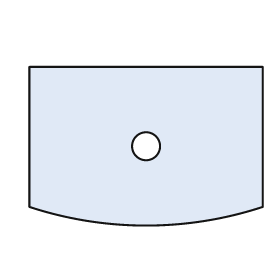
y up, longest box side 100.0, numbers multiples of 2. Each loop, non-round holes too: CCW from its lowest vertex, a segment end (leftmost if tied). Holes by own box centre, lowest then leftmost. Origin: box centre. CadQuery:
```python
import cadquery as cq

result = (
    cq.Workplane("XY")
    .moveTo(-50.0, -26.0)
    .threePointArc((0.0, -34.0), (50.0, -26.0))
    .lineTo(50.0, 34.0)
    .lineTo(-50.0, 34.0)
    .close()
    .moveTo(0.0, 0.0)
    .circle(6.0)
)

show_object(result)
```